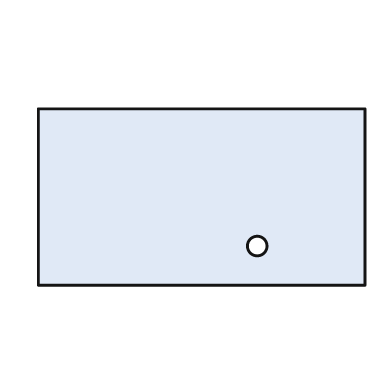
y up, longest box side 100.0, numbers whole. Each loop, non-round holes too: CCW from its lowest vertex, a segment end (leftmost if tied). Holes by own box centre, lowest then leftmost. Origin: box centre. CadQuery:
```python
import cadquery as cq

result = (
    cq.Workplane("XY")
    .moveTo(-50.0, -27.0)
    .lineTo(50.0, -27.0)
    .lineTo(50.0, 27.0)
    .lineTo(-50.0, 27.0)
    .close()
    .moveTo(17.0, -15.0)
    .circle(3.0)
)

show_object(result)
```